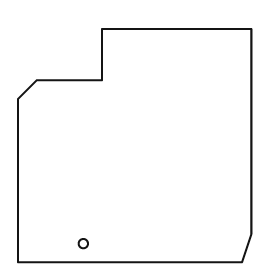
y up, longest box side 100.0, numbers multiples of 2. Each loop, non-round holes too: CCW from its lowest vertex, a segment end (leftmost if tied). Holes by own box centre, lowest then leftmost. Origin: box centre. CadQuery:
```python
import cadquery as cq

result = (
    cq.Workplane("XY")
    .moveTo(-50.0, -50.0)
    .lineTo(46.0, -50.0)
    .lineTo(50.0, -38.0)
    .lineTo(50.0, 50.0)
    .lineTo(-14.0, 50.0)
    .lineTo(-14.0, 28.0)
    .lineTo(-42.0, 28.0)
    .lineTo(-50.0, 20.0)
    .close()
    .moveTo(-22.0, -42.0)
    .circle(2.0)
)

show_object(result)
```